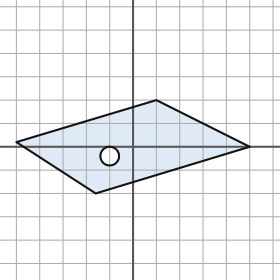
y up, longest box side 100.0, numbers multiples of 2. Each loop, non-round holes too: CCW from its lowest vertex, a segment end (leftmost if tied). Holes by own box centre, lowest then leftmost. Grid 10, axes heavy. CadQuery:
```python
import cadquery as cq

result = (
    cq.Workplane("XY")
    .moveTo(-16.0, -20.0)
    .lineTo(50.0, 0.0)
    .lineTo(10.0, 20.0)
    .lineTo(-50.0, 2.0)
    .close()
    .moveTo(-10.0, -4.0)
    .circle(4.0)
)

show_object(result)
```